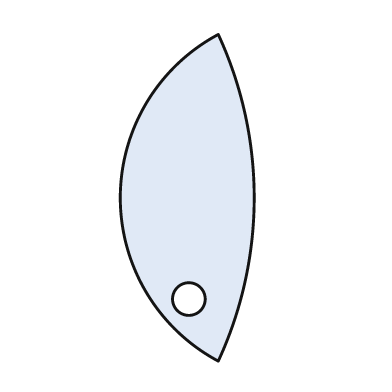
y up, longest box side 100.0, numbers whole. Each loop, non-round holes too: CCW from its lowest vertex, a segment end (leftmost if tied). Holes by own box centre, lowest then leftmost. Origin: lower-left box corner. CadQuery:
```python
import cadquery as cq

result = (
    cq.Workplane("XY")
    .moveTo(30.0, 0.0)
    .threePointArc((41.0, 50.0), (30.0, 100.0))
    .threePointArc((0.0, 50.0), (30.0, 0.0))
    .close()
    .moveTo(21.0, 19.0)
    .circle(5.0)
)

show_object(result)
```